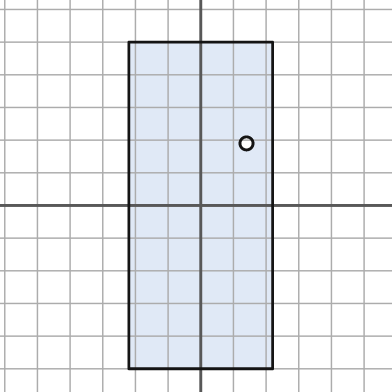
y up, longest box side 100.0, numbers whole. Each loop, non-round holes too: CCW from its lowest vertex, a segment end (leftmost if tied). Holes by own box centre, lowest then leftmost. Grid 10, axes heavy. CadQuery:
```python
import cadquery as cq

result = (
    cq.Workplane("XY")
    .moveTo(-22.0, -50.0)
    .lineTo(22.0, -50.0)
    .lineTo(22.0, 50.0)
    .lineTo(-22.0, 50.0)
    .close()
    .moveTo(14.0, 19.0)
    .circle(2.0)
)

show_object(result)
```